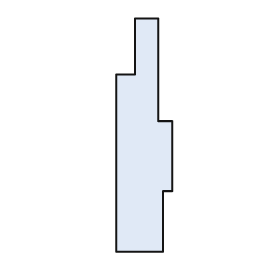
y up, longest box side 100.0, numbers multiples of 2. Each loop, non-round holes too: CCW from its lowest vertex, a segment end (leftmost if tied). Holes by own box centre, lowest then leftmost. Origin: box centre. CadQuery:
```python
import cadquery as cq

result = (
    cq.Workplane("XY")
    .moveTo(-12.0, -50.0)
    .lineTo(8.0, -50.0)
    .lineTo(8.0, -24.0)
    .lineTo(12.0, -24.0)
    .lineTo(12.0, 6.0)
    .lineTo(6.0, 6.0)
    .lineTo(6.0, 50.0)
    .lineTo(-4.0, 50.0)
    .lineTo(-4.0, 26.0)
    .lineTo(-12.0, 26.0)
    .close()
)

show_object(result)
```